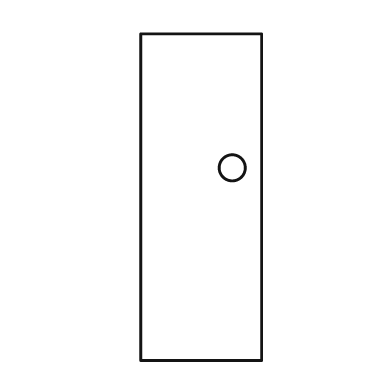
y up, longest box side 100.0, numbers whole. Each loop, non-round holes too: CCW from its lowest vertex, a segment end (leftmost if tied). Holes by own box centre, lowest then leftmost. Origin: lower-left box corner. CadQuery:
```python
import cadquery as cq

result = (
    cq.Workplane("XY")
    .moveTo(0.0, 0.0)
    .lineTo(37.0, 0.0)
    .lineTo(37.0, 100.0)
    .lineTo(0.0, 100.0)
    .close()
    .moveTo(28.0, 59.0)
    .circle(4.0)
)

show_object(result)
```